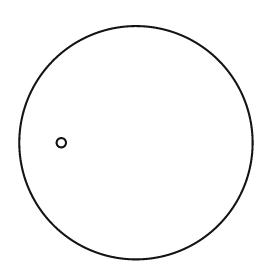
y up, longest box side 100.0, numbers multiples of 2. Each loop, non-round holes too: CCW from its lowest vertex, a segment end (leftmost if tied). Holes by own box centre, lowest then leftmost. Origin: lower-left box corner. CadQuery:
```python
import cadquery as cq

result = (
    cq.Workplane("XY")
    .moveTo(50.0, 50.0)
    .circle(50.0)
    .moveTo(18.0, 50.0)
    .circle(2.0)
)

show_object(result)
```